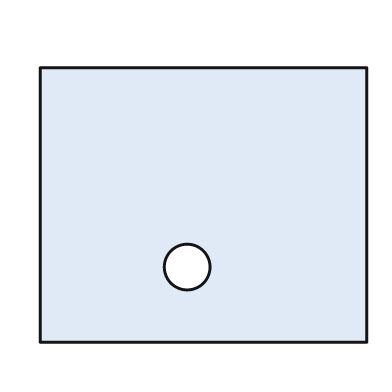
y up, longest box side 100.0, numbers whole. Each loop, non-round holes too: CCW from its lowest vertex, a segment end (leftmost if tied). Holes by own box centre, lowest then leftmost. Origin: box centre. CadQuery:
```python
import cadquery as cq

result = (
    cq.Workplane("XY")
    .moveTo(-50.0, -42.0)
    .lineTo(50.0, -42.0)
    .lineTo(50.0, 42.0)
    .lineTo(-50.0, 42.0)
    .close()
    .moveTo(-5.0, -19.0)
    .circle(7.0)
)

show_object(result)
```